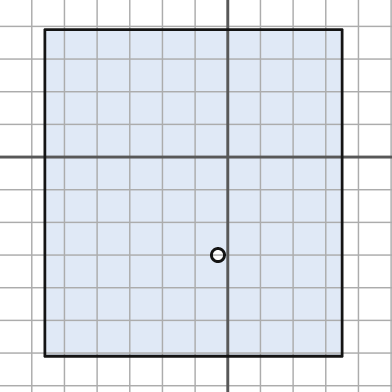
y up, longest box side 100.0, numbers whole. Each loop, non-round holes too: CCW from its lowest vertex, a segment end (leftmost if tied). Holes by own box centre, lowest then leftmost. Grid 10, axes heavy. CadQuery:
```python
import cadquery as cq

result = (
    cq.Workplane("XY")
    .moveTo(-56.0, -61.0)
    .lineTo(35.0, -61.0)
    .lineTo(35.0, 39.0)
    .lineTo(-56.0, 39.0)
    .close()
    .moveTo(-3.0, -30.0)
    .circle(2.0)
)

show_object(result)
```